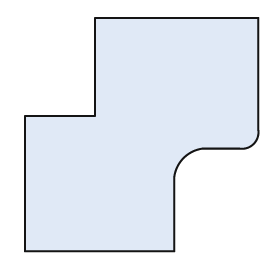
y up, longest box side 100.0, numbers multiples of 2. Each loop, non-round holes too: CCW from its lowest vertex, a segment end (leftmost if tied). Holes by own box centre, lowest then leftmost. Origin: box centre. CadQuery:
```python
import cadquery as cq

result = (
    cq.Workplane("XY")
    .moveTo(-50.0, -50.0)
    .lineTo(14.0, -50.0)
    .lineTo(14.0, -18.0)
    .threePointArc((18.0, -10.0), (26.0, -6.0))
    .lineTo(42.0, -6.0)
    .threePointArc((48.0, -4.0), (50.0, 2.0))
    .lineTo(50.0, 50.0)
    .lineTo(-20.0, 50.0)
    .lineTo(-20.0, 8.0)
    .lineTo(-50.0, 8.0)
    .close()
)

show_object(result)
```